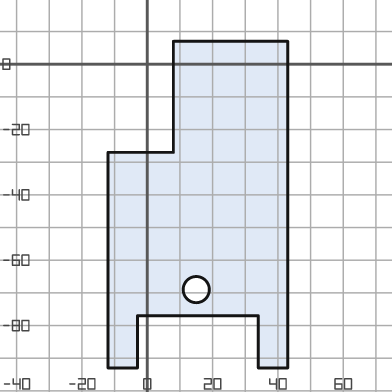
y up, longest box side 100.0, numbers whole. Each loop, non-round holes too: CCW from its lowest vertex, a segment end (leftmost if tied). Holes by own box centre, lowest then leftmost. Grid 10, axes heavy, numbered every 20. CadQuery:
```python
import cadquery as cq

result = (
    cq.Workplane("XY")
    .moveTo(-12.0, -93.0)
    .lineTo(-3.0, -93.0)
    .lineTo(-3.0, -77.0)
    .lineTo(34.0, -77.0)
    .lineTo(34.0, -93.0)
    .lineTo(43.0, -93.0)
    .lineTo(43.0, 7.0)
    .lineTo(8.0, 7.0)
    .lineTo(8.0, -27.0)
    .lineTo(-12.0, -27.0)
    .close()
    .moveTo(15.0, -69.0)
    .circle(4.0)
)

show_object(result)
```